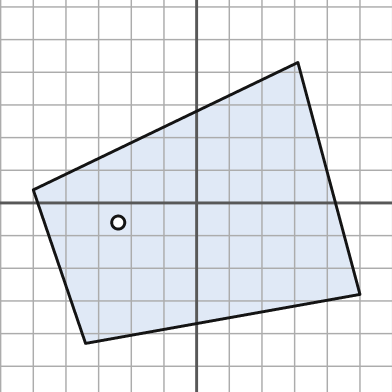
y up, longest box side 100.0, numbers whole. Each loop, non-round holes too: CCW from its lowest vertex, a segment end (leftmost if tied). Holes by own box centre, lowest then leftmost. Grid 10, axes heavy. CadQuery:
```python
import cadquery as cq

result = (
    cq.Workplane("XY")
    .moveTo(-34.0, -43.0)
    .lineTo(50.0, -28.0)
    .lineTo(31.0, 43.0)
    .lineTo(-50.0, 4.0)
    .close()
    .moveTo(-24.0, -6.0)
    .circle(2.0)
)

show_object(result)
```